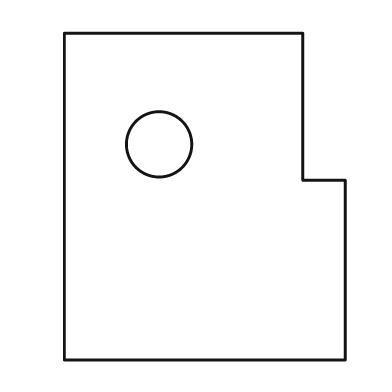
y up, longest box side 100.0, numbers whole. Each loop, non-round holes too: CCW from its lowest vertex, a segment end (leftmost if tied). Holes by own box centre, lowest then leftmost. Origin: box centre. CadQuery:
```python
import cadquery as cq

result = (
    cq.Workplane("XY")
    .moveTo(-43.0, -50.0)
    .lineTo(43.0, -50.0)
    .lineTo(43.0, 5.0)
    .lineTo(30.0, 5.0)
    .lineTo(30.0, 50.0)
    .lineTo(-43.0, 50.0)
    .close()
    .moveTo(-14.0, 16.0)
    .circle(10.0)
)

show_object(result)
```